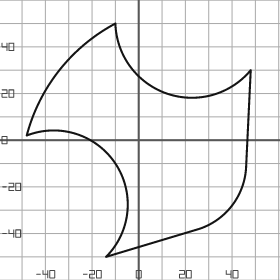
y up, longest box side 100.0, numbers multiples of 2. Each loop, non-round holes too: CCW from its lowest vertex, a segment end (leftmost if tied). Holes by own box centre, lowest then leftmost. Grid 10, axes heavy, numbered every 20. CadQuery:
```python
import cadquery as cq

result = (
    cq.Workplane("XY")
    .moveTo(-14.0, -50.0)
    .lineTo(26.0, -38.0)
    .threePointArc((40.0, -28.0), (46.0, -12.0))
    .lineTo(48.0, 30.0)
    .threePointArc((12.0, 20.0), (-10.0, 50.0))
    .threePointArc((-34.0, 30.0), (-48.0, 2.0))
    .threePointArc((-10.0, -10.0), (-14.0, -50.0))
    .close()
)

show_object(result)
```